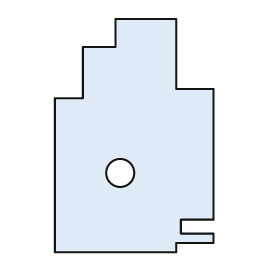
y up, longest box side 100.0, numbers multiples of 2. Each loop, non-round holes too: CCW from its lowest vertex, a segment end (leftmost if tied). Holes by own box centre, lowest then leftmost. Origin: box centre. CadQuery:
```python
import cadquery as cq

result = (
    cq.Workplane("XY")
    .moveTo(-34.0, -50.0)
    .lineTo(18.0, -50.0)
    .lineTo(18.0, -46.0)
    .lineTo(34.0, -46.0)
    .lineTo(34.0, -42.0)
    .lineTo(20.0, -42.0)
    .lineTo(20.0, -36.0)
    .lineTo(34.0, -36.0)
    .lineTo(34.0, 20.0)
    .lineTo(18.0, 20.0)
    .lineTo(18.0, 50.0)
    .lineTo(-8.0, 50.0)
    .lineTo(-8.0, 38.0)
    .lineTo(-22.0, 38.0)
    .lineTo(-22.0, 16.0)
    .lineTo(-34.0, 16.0)
    .close()
    .moveTo(-6.0, -16.0)
    .circle(6.0)
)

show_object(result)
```